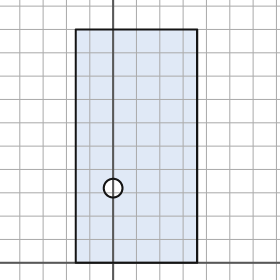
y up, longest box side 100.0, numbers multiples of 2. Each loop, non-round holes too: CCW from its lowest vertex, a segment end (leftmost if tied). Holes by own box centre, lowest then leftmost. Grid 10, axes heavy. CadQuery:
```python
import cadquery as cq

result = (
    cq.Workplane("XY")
    .moveTo(-16.0, 0.0)
    .lineTo(36.0, 0.0)
    .lineTo(36.0, 100.0)
    .lineTo(-16.0, 100.0)
    .close()
    .moveTo(0.0, 32.0)
    .circle(4.0)
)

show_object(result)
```